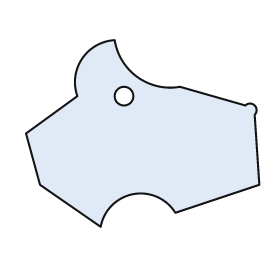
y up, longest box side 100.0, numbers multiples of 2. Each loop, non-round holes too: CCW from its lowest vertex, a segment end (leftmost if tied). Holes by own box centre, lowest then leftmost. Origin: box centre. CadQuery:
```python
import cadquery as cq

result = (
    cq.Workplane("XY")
    .moveTo(-18.0, -40.0)
    .threePointArc((-4.0, -26.0), (14.0, -34.0))
    .lineTo(50.0, -22.0)
    .lineTo(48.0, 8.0)
    .threePointArc((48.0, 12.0), (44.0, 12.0))
    .lineTo(16.0, 20.0)
    .threePointArc((-2.0, 24.0), (-12.0, 40.0))
    .threePointArc((-26.0, 32.0), (-28.0, 16.0))
    .lineTo(-50.0, 0.0)
    .lineTo(-44.0, -22.0)
    .close()
    .moveTo(-8.0, 16.0)
    .circle(4.0)
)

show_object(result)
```